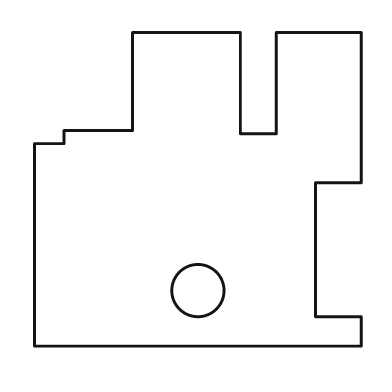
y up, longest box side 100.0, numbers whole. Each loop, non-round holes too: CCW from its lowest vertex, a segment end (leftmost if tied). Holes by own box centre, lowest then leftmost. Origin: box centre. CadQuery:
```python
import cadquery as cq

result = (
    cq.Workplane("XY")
    .moveTo(-50.0, -48.0)
    .lineTo(50.0, -48.0)
    .lineTo(50.0, -39.0)
    .lineTo(36.0, -39.0)
    .lineTo(36.0, 2.0)
    .lineTo(50.0, 2.0)
    .lineTo(50.0, 48.0)
    .lineTo(24.0, 48.0)
    .lineTo(24.0, 17.0)
    .lineTo(13.0, 17.0)
    .lineTo(13.0, 48.0)
    .lineTo(-20.0, 48.0)
    .lineTo(-20.0, 18.0)
    .lineTo(-41.0, 18.0)
    .lineTo(-41.0, 14.0)
    .lineTo(-50.0, 14.0)
    .close()
    .moveTo(0.0, -31.0)
    .circle(8.0)
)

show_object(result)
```